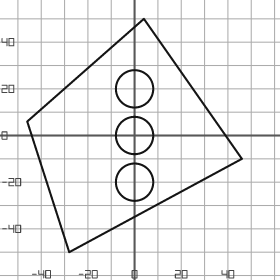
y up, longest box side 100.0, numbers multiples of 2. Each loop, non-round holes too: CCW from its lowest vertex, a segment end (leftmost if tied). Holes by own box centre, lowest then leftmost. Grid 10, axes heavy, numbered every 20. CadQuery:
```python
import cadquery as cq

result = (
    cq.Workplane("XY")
    .moveTo(-28.0, -50.0)
    .lineTo(46.0, -10.0)
    .lineTo(4.0, 50.0)
    .lineTo(-46.0, 6.0)
    .close()
    .moveTo(0.0, -20.0)
    .circle(8.0)
    .moveTo(0.0, 0.0)
    .circle(8.0)
    .moveTo(0.0, 20.0)
    .circle(8.0)
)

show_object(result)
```